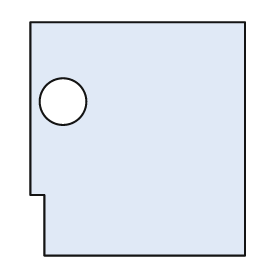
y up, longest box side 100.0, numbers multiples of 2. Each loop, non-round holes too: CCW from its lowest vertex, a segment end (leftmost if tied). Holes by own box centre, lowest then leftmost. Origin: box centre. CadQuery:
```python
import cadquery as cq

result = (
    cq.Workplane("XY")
    .moveTo(-40.0, -50.0)
    .lineTo(46.0, -50.0)
    .lineTo(46.0, 50.0)
    .lineTo(-46.0, 50.0)
    .lineTo(-46.0, -24.0)
    .lineTo(-40.0, -24.0)
    .close()
    .moveTo(-32.0, 16.0)
    .circle(10.0)
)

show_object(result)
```